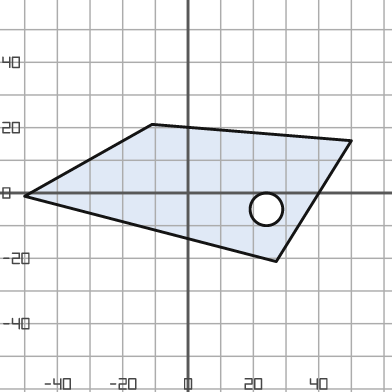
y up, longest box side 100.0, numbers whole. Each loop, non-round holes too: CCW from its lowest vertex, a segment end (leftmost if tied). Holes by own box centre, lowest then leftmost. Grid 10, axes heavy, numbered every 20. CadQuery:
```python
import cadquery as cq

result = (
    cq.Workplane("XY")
    .moveTo(27.0, -21.0)
    .lineTo(50.0, 16.0)
    .lineTo(-11.0, 21.0)
    .lineTo(-50.0, -1.0)
    .close()
    .moveTo(24.0, -5.0)
    .circle(5.0)
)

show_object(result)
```